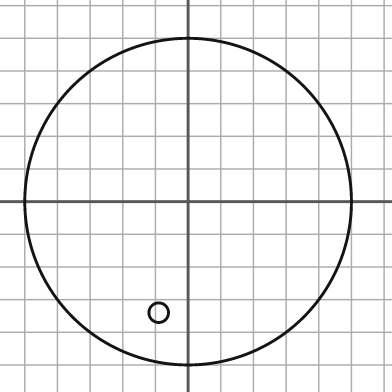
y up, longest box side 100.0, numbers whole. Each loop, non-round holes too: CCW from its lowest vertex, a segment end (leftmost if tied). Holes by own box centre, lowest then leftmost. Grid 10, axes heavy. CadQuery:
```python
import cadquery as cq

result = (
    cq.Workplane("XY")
    .moveTo(0.0, 0.0)
    .circle(50.0)
    .moveTo(-9.0, -34.0)
    .circle(3.0)
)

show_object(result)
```